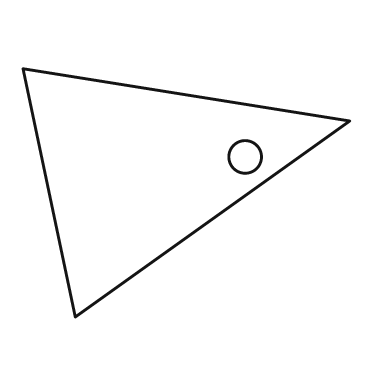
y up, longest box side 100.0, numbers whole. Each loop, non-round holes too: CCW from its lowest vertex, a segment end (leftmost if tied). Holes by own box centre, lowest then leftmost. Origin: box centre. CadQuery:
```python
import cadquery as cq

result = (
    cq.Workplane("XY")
    .moveTo(-34.0, -38.0)
    .lineTo(50.0, 22.0)
    .lineTo(-50.0, 38.0)
    .close()
    .moveTo(18.0, 11.0)
    .circle(5.0)
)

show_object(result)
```